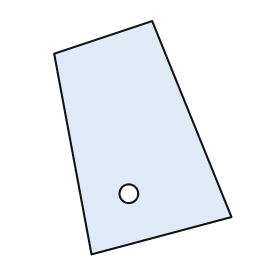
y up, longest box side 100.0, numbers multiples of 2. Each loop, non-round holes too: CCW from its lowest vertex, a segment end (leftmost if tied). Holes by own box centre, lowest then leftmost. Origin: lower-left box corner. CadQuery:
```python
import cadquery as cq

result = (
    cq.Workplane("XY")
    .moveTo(16.0, 0.0)
    .lineTo(76.0, 16.0)
    .lineTo(42.0, 100.0)
    .lineTo(0.0, 86.0)
    .close()
    .moveTo(32.0, 26.0)
    .circle(4.0)
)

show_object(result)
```